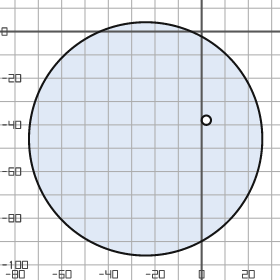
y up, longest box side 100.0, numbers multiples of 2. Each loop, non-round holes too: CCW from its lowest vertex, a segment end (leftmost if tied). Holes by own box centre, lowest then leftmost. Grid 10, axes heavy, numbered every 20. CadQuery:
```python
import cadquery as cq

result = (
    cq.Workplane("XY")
    .moveTo(-24.0, -46.0)
    .circle(50.0)
    .moveTo(2.0, -38.0)
    .circle(2.0)
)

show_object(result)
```